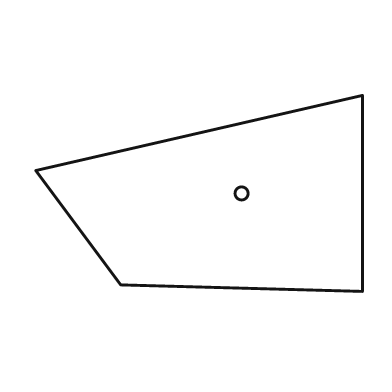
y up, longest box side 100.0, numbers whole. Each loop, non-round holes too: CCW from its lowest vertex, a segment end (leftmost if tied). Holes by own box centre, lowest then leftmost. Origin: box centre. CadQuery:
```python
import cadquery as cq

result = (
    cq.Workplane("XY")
    .moveTo(50.0, -30.0)
    .lineTo(50.0, 30.0)
    .lineTo(-50.0, 7.0)
    .lineTo(-24.0, -28.0)
    .close()
    .moveTo(13.0, 0.0)
    .circle(2.0)
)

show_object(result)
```